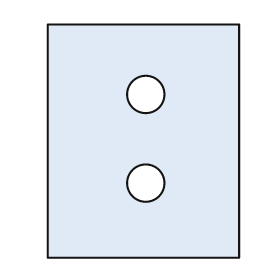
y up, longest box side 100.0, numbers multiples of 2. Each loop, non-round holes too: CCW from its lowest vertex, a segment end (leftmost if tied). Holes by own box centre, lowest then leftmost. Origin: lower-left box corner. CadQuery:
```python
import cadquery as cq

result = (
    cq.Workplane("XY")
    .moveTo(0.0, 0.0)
    .lineTo(82.0, 0.0)
    .lineTo(82.0, 100.0)
    .lineTo(0.0, 100.0)
    .close()
    .moveTo(42.0, 32.0)
    .circle(8.0)
    .moveTo(42.0, 70.0)
    .circle(8.0)
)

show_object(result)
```